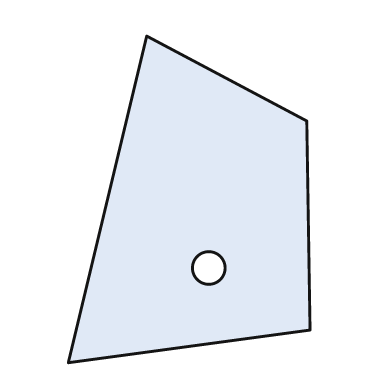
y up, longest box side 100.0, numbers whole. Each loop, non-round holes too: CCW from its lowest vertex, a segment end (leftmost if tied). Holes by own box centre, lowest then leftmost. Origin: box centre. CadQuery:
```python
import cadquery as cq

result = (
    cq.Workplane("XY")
    .moveTo(-37.0, -50.0)
    .lineTo(37.0, -40.0)
    .lineTo(36.0, 24.0)
    .lineTo(-13.0, 50.0)
    .close()
    .moveTo(6.0, -21.0)
    .circle(5.0)
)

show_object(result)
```